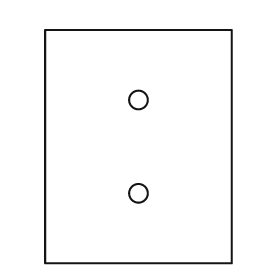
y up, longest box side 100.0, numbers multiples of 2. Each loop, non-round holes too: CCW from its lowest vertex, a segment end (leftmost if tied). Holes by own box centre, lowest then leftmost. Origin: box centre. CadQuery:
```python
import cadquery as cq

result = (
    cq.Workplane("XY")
    .moveTo(-40.0, -50.0)
    .lineTo(40.0, -50.0)
    .lineTo(40.0, 50.0)
    .lineTo(-40.0, 50.0)
    .close()
    .moveTo(0.0, -20.0)
    .circle(4.0)
    .moveTo(0.0, 20.0)
    .circle(4.0)
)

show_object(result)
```